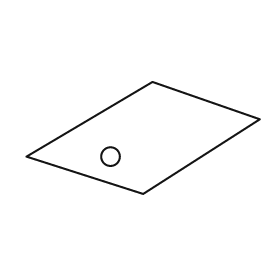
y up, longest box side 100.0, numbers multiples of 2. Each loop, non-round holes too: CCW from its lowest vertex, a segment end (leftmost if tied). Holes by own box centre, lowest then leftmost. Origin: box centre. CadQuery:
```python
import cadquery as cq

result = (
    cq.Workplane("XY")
    .moveTo(0.0, -24.0)
    .lineTo(50.0, 8.0)
    .lineTo(4.0, 24.0)
    .lineTo(-50.0, -8.0)
    .close()
    .moveTo(-14.0, -8.0)
    .circle(4.0)
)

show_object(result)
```